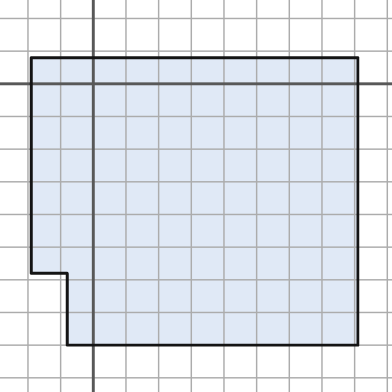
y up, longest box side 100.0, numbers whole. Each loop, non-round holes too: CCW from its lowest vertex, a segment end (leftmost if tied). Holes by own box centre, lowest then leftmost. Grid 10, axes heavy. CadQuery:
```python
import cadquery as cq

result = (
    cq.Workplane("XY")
    .moveTo(-8.0, -80.0)
    .lineTo(81.0, -80.0)
    .lineTo(81.0, 8.0)
    .lineTo(-19.0, 8.0)
    .lineTo(-19.0, -58.0)
    .lineTo(-8.0, -58.0)
    .close()
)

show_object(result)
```